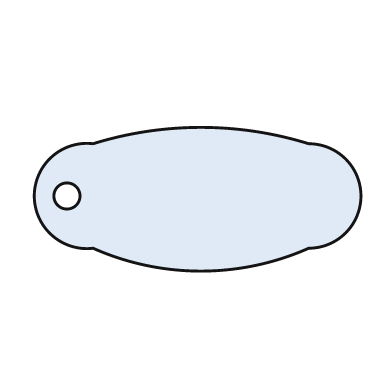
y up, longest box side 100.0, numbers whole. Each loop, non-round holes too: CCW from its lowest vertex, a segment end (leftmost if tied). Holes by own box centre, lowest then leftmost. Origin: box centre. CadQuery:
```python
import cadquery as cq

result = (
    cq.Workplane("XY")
    .moveTo(-32.0, -15.0)
    .threePointArc((1.0, -22.0), (34.0, -15.0))
    .threePointArc((50.0, 1.0), (34.0, 17.0))
    .threePointArc((1.0, 22.0), (-32.0, 17.0))
    .threePointArc((-50.0, 1.0), (-32.0, -15.0))
    .close()
    .moveTo(-40.0, 1.0)
    .circle(4.0)
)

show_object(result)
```